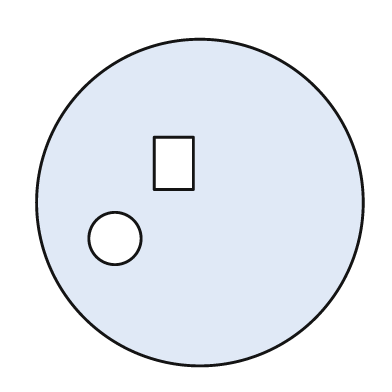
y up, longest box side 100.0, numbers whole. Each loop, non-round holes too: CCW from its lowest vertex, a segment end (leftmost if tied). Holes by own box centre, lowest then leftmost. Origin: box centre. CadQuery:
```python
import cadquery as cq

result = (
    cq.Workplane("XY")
    .moveTo(0.0, 0.0)
    .circle(50.0)
    .moveTo(-26.0, -11.0)
    .circle(8.0)
    .moveTo(-14.0, 4.0)
    .lineTo(-2.0, 4.0)
    .lineTo(-2.0, 20.0)
    .lineTo(-14.0, 20.0)
    .close()
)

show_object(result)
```